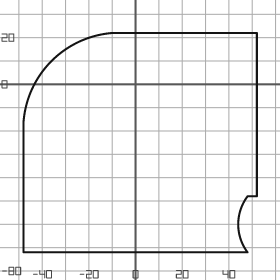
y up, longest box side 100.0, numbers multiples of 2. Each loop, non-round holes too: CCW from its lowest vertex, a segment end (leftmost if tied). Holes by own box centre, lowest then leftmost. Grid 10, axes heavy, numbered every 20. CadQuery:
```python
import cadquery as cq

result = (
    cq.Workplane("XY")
    .moveTo(-48.0, -72.0)
    .lineTo(48.0, -72.0)
    .threePointArc((44.0, -60.0), (48.0, -48.0))
    .lineTo(52.0, -48.0)
    .lineTo(52.0, 22.0)
    .lineTo(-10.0, 22.0)
    .threePointArc((-36.0, 10.0), (-48.0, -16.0))
    .close()
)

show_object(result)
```